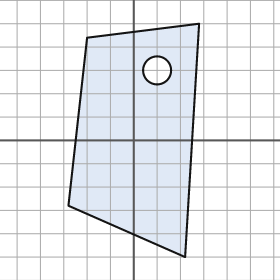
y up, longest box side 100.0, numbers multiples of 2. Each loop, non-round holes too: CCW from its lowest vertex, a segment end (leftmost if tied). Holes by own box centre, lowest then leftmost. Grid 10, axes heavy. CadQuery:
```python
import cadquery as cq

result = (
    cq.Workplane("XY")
    .moveTo(22.0, -50.0)
    .lineTo(28.0, 50.0)
    .lineTo(-20.0, 44.0)
    .lineTo(-28.0, -28.0)
    .close()
    .moveTo(10.0, 30.0)
    .circle(6.0)
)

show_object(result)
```